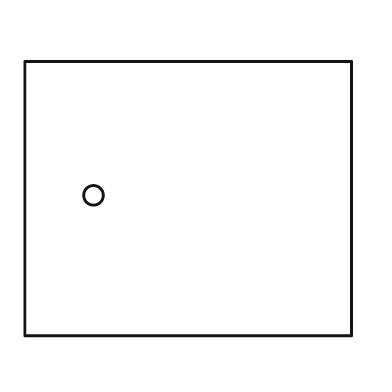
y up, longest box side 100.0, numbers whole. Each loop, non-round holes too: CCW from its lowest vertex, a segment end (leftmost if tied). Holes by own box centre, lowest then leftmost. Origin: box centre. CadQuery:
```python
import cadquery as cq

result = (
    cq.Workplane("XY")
    .moveTo(-50.0, -42.0)
    .lineTo(50.0, -42.0)
    .lineTo(50.0, 42.0)
    .lineTo(-50.0, 42.0)
    .close()
    .moveTo(-29.0, 1.0)
    .circle(3.0)
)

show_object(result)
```